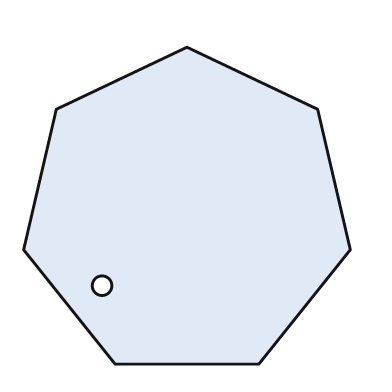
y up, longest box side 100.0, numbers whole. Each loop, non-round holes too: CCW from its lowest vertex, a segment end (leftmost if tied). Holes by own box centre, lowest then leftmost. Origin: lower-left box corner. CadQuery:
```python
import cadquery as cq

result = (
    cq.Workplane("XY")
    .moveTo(28.0, 0.0)
    .lineTo(72.0, 0.0)
    .lineTo(100.0, 35.0)
    .lineTo(90.0, 78.0)
    .lineTo(50.0, 97.0)
    .lineTo(10.0, 78.0)
    .lineTo(0.0, 35.0)
    .close()
    .moveTo(24.0, 24.0)
    .circle(3.0)
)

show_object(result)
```